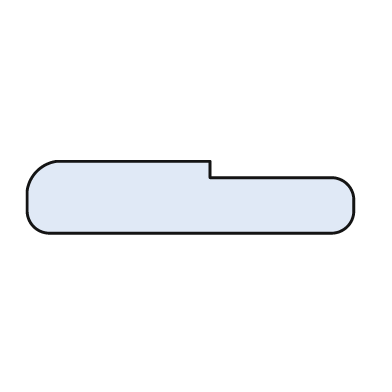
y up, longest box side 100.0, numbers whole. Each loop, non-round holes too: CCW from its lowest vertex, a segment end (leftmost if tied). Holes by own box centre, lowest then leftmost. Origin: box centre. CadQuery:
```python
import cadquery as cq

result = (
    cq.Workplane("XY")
    .moveTo(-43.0, -11.0)
    .lineTo(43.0, -11.0)
    .threePointArc((48.0, -9.0), (50.0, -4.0))
    .lineTo(50.0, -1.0)
    .threePointArc((48.0, 4.0), (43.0, 6.0))
    .lineTo(6.0, 6.0)
    .lineTo(6.0, 11.0)
    .lineTo(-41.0, 11.0)
    .threePointArc((-47.0, 8.0), (-50.0, 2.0))
    .lineTo(-50.0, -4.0)
    .threePointArc((-48.0, -9.0), (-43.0, -11.0))
    .close()
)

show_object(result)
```